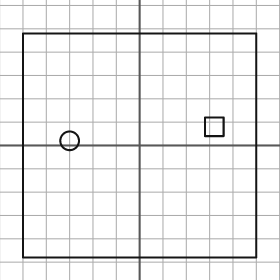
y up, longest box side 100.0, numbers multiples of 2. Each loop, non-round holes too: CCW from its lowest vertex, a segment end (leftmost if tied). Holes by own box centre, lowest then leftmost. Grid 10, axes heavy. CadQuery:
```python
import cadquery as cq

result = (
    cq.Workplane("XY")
    .moveTo(-50.0, -48.0)
    .lineTo(50.0, -48.0)
    .lineTo(50.0, 48.0)
    .lineTo(-50.0, 48.0)
    .close()
    .moveTo(-30.0, 2.0)
    .circle(4.0)
    .moveTo(28.0, 4.0)
    .lineTo(36.0, 4.0)
    .lineTo(36.0, 12.0)
    .lineTo(28.0, 12.0)
    .close()
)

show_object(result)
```